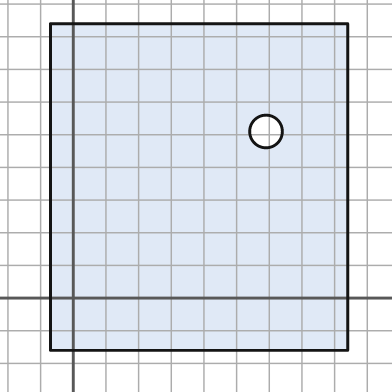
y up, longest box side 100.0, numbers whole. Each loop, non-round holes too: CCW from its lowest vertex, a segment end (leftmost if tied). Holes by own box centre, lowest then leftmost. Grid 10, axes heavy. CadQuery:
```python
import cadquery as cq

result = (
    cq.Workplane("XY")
    .moveTo(-7.0, -16.0)
    .lineTo(84.0, -16.0)
    .lineTo(84.0, 84.0)
    .lineTo(-7.0, 84.0)
    .close()
    .moveTo(59.0, 51.0)
    .circle(5.0)
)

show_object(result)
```